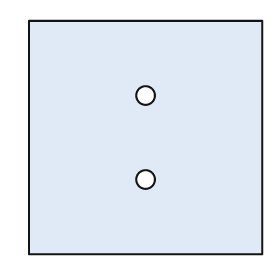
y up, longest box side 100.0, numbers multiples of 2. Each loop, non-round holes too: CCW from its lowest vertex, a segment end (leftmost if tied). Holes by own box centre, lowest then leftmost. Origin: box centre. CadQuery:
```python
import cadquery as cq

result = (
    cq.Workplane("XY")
    .moveTo(-50.0, -50.0)
    .lineTo(50.0, -50.0)
    .lineTo(50.0, 50.0)
    .lineTo(-50.0, 50.0)
    .close()
    .moveTo(0.0, -18.0)
    .circle(4.0)
    .moveTo(0.0, 18.0)
    .circle(4.0)
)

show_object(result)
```